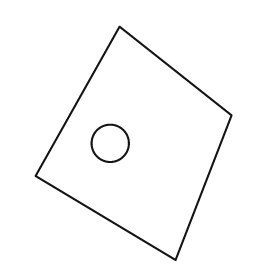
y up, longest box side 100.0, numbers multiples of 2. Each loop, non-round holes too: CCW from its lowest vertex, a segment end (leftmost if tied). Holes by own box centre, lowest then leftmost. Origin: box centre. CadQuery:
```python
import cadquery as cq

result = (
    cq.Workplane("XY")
    .moveTo(18.0, -50.0)
    .lineTo(42.0, 12.0)
    .lineTo(-6.0, 50.0)
    .lineTo(-42.0, -14.0)
    .close()
    .moveTo(-10.0, 0.0)
    .circle(8.0)
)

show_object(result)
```